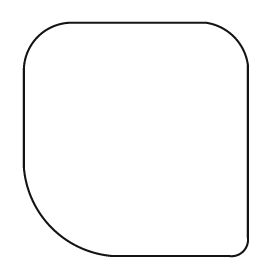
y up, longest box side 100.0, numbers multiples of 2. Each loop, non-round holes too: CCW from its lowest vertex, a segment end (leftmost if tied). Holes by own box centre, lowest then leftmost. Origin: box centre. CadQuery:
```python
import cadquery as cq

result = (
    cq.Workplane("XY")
    .moveTo(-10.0, -50.0)
    .lineTo(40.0, -50.0)
    .threePointArc((46.0, -48.0), (48.0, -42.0))
    .lineTo(48.0, 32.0)
    .threePointArc((42.0, 44.0), (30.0, 50.0))
    .lineTo(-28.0, 50.0)
    .threePointArc((-42.0, 44.0), (-48.0, 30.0))
    .lineTo(-48.0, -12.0)
    .threePointArc((-36.0, -38.0), (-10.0, -50.0))
    .close()
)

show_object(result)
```